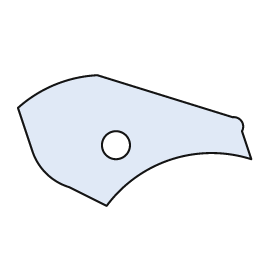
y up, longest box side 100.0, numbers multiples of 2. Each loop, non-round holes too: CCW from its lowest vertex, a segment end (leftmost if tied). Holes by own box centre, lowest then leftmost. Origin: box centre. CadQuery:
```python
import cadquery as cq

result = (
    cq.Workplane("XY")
    .moveTo(-12.0, -28.0)
    .threePointArc((16.0, -8.0), (50.0, -8.0))
    .lineTo(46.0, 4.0)
    .threePointArc((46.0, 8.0), (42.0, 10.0))
    .lineTo(-16.0, 28.0)
    .threePointArc((-34.0, 24.0), (-50.0, 14.0))
    .lineTo(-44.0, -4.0)
    .threePointArc((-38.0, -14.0), (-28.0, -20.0))
    .close()
    .moveTo(-8.0, -2.0)
    .circle(6.0)
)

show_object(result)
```